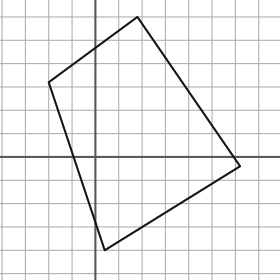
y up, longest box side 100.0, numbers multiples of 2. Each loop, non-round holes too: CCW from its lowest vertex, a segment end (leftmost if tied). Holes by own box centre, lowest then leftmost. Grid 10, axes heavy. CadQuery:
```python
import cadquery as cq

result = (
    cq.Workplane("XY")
    .moveTo(4.0, -40.0)
    .lineTo(62.0, -4.0)
    .lineTo(18.0, 60.0)
    .lineTo(-20.0, 32.0)
    .close()
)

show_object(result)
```